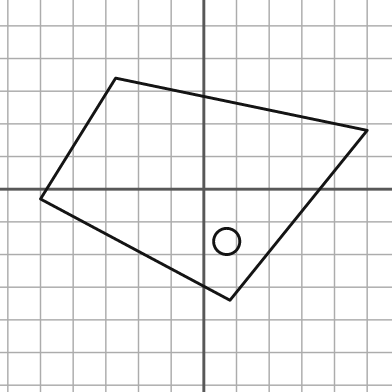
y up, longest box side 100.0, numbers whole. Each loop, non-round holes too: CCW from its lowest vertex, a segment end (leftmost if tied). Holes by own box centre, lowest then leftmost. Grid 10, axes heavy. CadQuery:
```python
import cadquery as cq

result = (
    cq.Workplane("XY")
    .moveTo(8.0, -34.0)
    .lineTo(50.0, 18.0)
    .lineTo(-27.0, 34.0)
    .lineTo(-50.0, -3.0)
    .close()
    .moveTo(7.0, -16.0)
    .circle(4.0)
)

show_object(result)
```